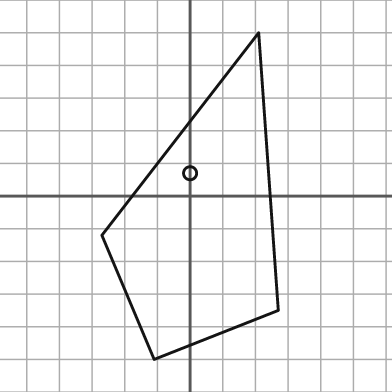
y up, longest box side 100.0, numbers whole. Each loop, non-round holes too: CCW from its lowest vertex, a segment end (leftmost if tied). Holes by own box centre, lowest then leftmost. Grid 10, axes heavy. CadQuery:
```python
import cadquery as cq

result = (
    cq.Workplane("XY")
    .moveTo(-11.0, -50.0)
    .lineTo(27.0, -35.0)
    .lineTo(21.0, 50.0)
    .lineTo(-27.0, -12.0)
    .close()
    .moveTo(0.0, 7.0)
    .circle(2.0)
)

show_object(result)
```